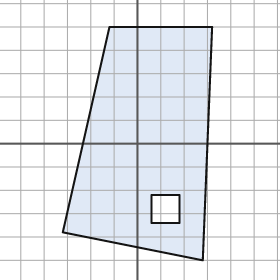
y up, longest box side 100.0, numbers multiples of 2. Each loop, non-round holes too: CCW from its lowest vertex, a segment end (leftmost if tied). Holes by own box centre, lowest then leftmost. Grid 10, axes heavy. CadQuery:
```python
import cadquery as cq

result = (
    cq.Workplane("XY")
    .moveTo(28.0, -50.0)
    .lineTo(32.0, 50.0)
    .lineTo(-12.0, 50.0)
    .lineTo(-32.0, -38.0)
    .close()
    .moveTo(6.0, -34.0)
    .lineTo(18.0, -34.0)
    .lineTo(18.0, -22.0)
    .lineTo(6.0, -22.0)
    .close()
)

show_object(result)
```